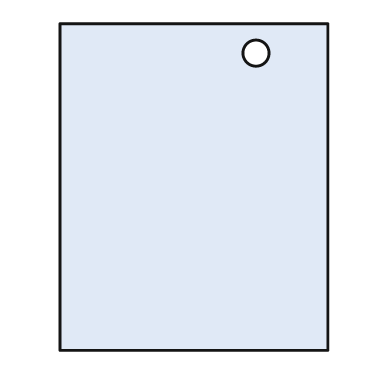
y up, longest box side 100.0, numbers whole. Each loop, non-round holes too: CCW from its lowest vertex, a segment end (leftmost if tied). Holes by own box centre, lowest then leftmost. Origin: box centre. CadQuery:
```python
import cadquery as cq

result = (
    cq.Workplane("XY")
    .moveTo(-41.0, -50.0)
    .lineTo(41.0, -50.0)
    .lineTo(41.0, 50.0)
    .lineTo(-41.0, 50.0)
    .close()
    .moveTo(19.0, 41.0)
    .circle(4.0)
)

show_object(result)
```